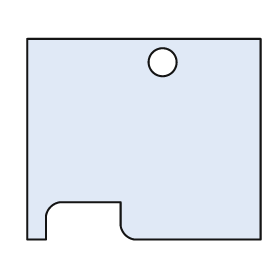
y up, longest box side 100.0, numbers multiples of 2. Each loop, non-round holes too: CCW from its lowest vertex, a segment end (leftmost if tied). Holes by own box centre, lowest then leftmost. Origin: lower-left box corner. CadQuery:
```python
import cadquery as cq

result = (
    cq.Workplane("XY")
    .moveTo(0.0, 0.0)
    .lineTo(8.0, 0.0)
    .lineTo(8.0, 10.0)
    .threePointArc((10.0, 14.0), (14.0, 16.0))
    .lineTo(40.0, 16.0)
    .lineTo(40.0, 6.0)
    .threePointArc((42.0, 2.0), (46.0, 0.0))
    .lineTo(100.0, 0.0)
    .lineTo(100.0, 86.0)
    .lineTo(0.0, 86.0)
    .close()
    .moveTo(58.0, 76.0)
    .circle(6.0)
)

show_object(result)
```